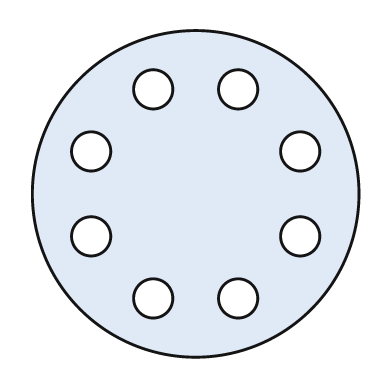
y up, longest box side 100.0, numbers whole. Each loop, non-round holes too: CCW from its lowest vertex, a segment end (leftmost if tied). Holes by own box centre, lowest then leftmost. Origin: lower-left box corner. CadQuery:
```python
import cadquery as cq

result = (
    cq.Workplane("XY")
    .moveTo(50.0, 50.0)
    .circle(50.0)
    .moveTo(37.0, 18.0)
    .circle(6.0)
    .moveTo(63.0, 18.0)
    .circle(6.0)
    .moveTo(18.0, 37.0)
    .circle(6.0)
    .moveTo(82.0, 37.0)
    .circle(6.0)
    .moveTo(18.0, 63.0)
    .circle(6.0)
    .moveTo(82.0, 63.0)
    .circle(6.0)
    .moveTo(37.0, 82.0)
    .circle(6.0)
    .moveTo(63.0, 82.0)
    .circle(6.0)
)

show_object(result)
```